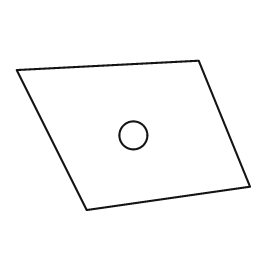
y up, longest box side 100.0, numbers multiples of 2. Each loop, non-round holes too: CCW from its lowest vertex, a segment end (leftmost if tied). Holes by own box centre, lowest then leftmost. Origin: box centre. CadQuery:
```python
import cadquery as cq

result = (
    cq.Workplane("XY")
    .moveTo(-20.0, -32.0)
    .lineTo(50.0, -22.0)
    .lineTo(28.0, 32.0)
    .lineTo(-50.0, 28.0)
    .close()
    .moveTo(0.0, 0.0)
    .circle(6.0)
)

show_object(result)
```